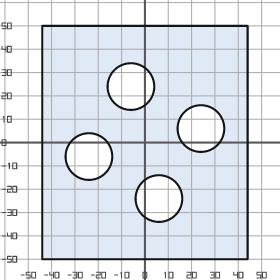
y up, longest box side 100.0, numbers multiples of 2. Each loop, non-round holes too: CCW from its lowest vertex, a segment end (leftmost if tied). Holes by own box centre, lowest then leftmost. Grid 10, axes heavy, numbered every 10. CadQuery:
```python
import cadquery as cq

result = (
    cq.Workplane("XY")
    .moveTo(-44.0, -50.0)
    .lineTo(44.0, -50.0)
    .lineTo(44.0, 50.0)
    .lineTo(-44.0, 50.0)
    .close()
    .moveTo(6.0, -24.0)
    .circle(10.0)
    .moveTo(-24.0, -6.0)
    .circle(10.0)
    .moveTo(24.0, 6.0)
    .circle(10.0)
    .moveTo(-6.0, 24.0)
    .circle(10.0)
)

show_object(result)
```